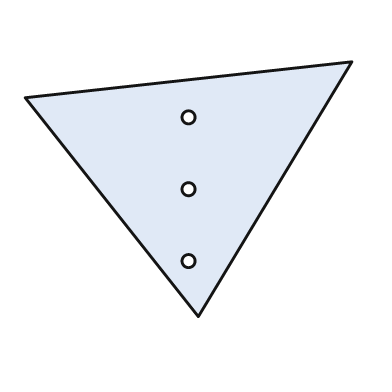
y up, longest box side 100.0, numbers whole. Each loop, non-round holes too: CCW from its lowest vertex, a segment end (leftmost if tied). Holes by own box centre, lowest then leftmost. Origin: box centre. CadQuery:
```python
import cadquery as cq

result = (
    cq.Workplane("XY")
    .moveTo(3.0, -39.0)
    .lineTo(50.0, 39.0)
    .lineTo(-50.0, 28.0)
    .close()
    .moveTo(0.0, -22.0)
    .circle(2.0)
    .moveTo(0.0, 0.0)
    .circle(2.0)
    .moveTo(0.0, 22.0)
    .circle(2.0)
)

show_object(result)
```